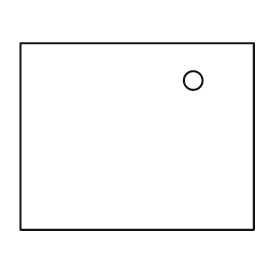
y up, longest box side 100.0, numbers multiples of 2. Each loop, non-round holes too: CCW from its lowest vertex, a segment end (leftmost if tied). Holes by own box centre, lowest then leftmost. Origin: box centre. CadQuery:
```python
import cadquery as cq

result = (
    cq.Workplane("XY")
    .moveTo(-50.0, -40.0)
    .lineTo(50.0, -40.0)
    .lineTo(50.0, 40.0)
    .lineTo(-50.0, 40.0)
    .close()
    .moveTo(24.0, 24.0)
    .circle(4.0)
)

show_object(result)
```